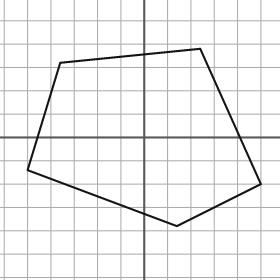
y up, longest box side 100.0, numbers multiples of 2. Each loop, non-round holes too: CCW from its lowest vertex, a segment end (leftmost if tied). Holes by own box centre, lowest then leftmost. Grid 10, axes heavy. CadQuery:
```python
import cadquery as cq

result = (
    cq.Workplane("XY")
    .moveTo(14.0, -38.0)
    .lineTo(50.0, -20.0)
    .lineTo(24.0, 38.0)
    .lineTo(-36.0, 32.0)
    .lineTo(-50.0, -14.0)
    .close()
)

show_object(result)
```